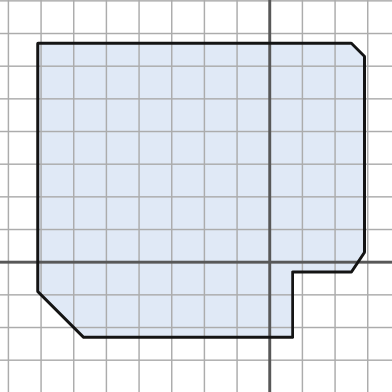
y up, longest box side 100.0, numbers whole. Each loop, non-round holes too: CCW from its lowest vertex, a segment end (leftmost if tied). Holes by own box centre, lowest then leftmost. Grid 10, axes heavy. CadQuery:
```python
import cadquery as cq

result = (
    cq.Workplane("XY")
    .moveTo(-57.0, -23.0)
    .lineTo(7.0, -23.0)
    .lineTo(7.0, -3.0)
    .lineTo(25.0, -3.0)
    .lineTo(29.0, 3.0)
    .lineTo(29.0, 63.0)
    .lineTo(25.0, 67.0)
    .lineTo(-71.0, 67.0)
    .lineTo(-71.0, -9.0)
    .close()
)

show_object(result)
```